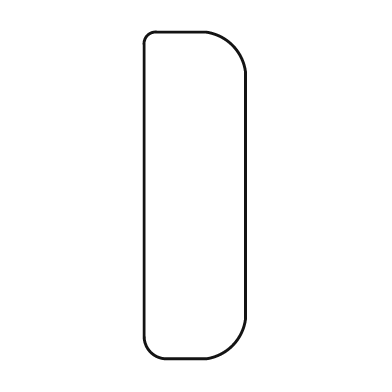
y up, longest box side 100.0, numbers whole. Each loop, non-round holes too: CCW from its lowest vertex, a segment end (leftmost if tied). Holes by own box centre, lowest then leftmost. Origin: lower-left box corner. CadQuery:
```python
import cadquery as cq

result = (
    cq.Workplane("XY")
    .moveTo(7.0, 0.0)
    .lineTo(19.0, 0.0)
    .threePointArc((27.0, 4.0), (31.0, 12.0))
    .lineTo(31.0, 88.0)
    .threePointArc((27.0, 96.0), (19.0, 100.0))
    .lineTo(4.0, 100.0)
    .threePointArc((1.0, 99.0), (0.0, 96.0))
    .lineTo(0.0, 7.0)
    .threePointArc((2.0, 2.0), (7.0, 0.0))
    .close()
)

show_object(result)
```